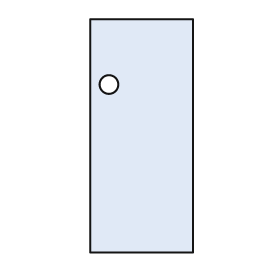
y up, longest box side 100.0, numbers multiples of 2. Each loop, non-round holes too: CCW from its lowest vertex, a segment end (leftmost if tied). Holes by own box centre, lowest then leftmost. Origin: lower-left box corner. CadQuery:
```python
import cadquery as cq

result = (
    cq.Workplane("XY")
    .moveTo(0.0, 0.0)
    .lineTo(44.0, 0.0)
    .lineTo(44.0, 100.0)
    .lineTo(0.0, 100.0)
    .close()
    .moveTo(8.0, 72.0)
    .circle(4.0)
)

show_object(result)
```